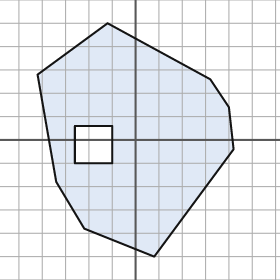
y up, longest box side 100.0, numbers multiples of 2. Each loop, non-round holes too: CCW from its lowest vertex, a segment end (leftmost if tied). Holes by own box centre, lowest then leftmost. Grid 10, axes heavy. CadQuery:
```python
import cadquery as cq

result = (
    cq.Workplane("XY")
    .moveTo(8.0, -50.0)
    .lineTo(42.0, -4.0)
    .lineTo(40.0, 14.0)
    .lineTo(32.0, 26.0)
    .lineTo(-12.0, 50.0)
    .lineTo(-42.0, 28.0)
    .lineTo(-34.0, -18.0)
    .lineTo(-22.0, -38.0)
    .close()
    .moveTo(-26.0, -10.0)
    .lineTo(-10.0, -10.0)
    .lineTo(-10.0, 6.0)
    .lineTo(-26.0, 6.0)
    .close()
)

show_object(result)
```